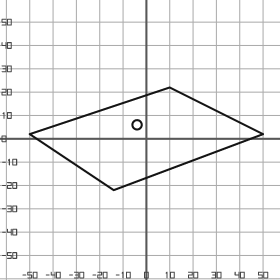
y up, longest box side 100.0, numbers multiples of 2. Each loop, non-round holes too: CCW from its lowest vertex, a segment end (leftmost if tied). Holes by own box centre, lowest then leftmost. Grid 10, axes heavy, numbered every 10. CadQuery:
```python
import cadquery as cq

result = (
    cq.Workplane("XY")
    .moveTo(-14.0, -22.0)
    .lineTo(50.0, 2.0)
    .lineTo(10.0, 22.0)
    .lineTo(-50.0, 2.0)
    .close()
    .moveTo(-4.0, 6.0)
    .circle(2.0)
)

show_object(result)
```